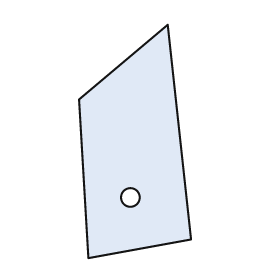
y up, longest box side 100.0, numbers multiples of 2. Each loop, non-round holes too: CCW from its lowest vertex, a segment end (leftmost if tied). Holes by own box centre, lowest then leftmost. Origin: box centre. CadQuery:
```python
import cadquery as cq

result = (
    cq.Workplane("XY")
    .moveTo(-20.0, -50.0)
    .lineTo(24.0, -42.0)
    .lineTo(14.0, 50.0)
    .lineTo(-24.0, 18.0)
    .close()
    .moveTo(-2.0, -24.0)
    .circle(4.0)
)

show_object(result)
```